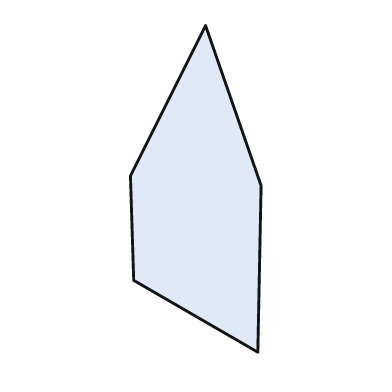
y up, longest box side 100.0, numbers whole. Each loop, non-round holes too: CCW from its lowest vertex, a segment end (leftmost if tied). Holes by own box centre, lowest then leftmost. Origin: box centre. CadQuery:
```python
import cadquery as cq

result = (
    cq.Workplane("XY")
    .moveTo(19.0, -50.0)
    .lineTo(20.0, 1.0)
    .lineTo(3.0, 50.0)
    .lineTo(-20.0, 4.0)
    .lineTo(-19.0, -28.0)
    .close()
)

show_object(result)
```